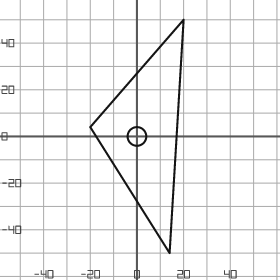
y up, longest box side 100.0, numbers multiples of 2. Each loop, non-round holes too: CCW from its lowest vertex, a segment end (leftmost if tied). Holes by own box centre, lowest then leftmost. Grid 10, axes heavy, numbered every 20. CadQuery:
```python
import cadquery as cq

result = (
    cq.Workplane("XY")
    .moveTo(14.0, -50.0)
    .lineTo(20.0, 50.0)
    .lineTo(-20.0, 4.0)
    .close()
    .moveTo(0.0, 0.0)
    .circle(4.0)
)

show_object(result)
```